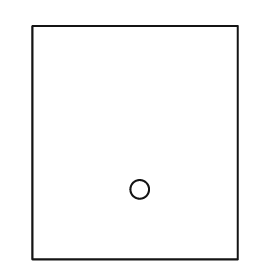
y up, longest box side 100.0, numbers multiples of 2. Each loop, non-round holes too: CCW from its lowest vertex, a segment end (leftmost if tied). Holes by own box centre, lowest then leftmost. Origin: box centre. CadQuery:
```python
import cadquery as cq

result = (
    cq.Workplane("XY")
    .moveTo(-44.0, -50.0)
    .lineTo(44.0, -50.0)
    .lineTo(44.0, 50.0)
    .lineTo(-44.0, 50.0)
    .close()
    .moveTo(2.0, -20.0)
    .circle(4.0)
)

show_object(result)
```